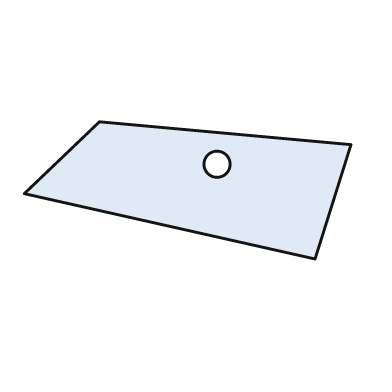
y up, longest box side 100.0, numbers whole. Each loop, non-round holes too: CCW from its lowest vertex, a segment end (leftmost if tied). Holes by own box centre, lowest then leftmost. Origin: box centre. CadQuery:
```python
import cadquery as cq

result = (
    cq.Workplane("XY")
    .moveTo(39.0, -21.0)
    .lineTo(50.0, 14.0)
    .lineTo(-27.0, 21.0)
    .lineTo(-50.0, -1.0)
    .close()
    .moveTo(9.0, 8.0)
    .circle(4.0)
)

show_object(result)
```